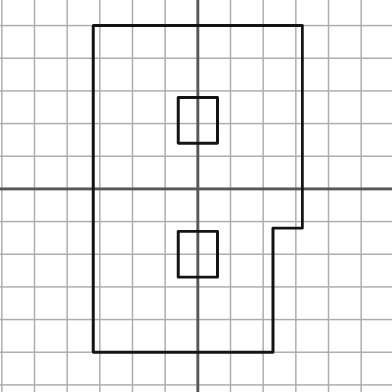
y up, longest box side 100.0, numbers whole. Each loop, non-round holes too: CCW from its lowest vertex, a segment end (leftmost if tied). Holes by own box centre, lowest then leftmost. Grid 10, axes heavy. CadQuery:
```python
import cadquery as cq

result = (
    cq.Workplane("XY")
    .moveTo(-32.0, -50.0)
    .lineTo(23.0, -50.0)
    .lineTo(23.0, -12.0)
    .lineTo(32.0, -12.0)
    .lineTo(32.0, 50.0)
    .lineTo(-32.0, 50.0)
    .close()
    .moveTo(-6.0, -27.0)
    .lineTo(6.0, -27.0)
    .lineTo(6.0, -13.0)
    .lineTo(-6.0, -13.0)
    .close()
    .moveTo(-6.0, 14.0)
    .lineTo(6.0, 14.0)
    .lineTo(6.0, 28.0)
    .lineTo(-6.0, 28.0)
    .close()
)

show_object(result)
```